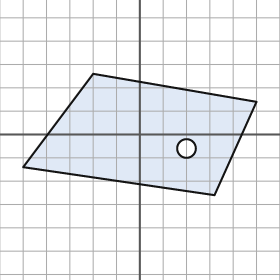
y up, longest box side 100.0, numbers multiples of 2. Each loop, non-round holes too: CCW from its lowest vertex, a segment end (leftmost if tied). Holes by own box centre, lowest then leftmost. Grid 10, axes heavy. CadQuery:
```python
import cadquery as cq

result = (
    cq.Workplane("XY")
    .moveTo(32.0, -26.0)
    .lineTo(50.0, 14.0)
    .lineTo(-20.0, 26.0)
    .lineTo(-50.0, -14.0)
    .close()
    .moveTo(20.0, -6.0)
    .circle(4.0)
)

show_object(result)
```